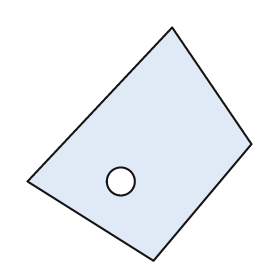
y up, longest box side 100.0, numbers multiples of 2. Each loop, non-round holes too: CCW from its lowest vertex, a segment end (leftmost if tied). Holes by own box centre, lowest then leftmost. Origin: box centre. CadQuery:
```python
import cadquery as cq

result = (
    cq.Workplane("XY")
    .moveTo(6.0, -50.0)
    .lineTo(48.0, 0.0)
    .lineTo(14.0, 50.0)
    .lineTo(-48.0, -16.0)
    .close()
    .moveTo(-8.0, -16.0)
    .circle(6.0)
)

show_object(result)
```